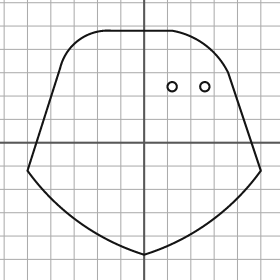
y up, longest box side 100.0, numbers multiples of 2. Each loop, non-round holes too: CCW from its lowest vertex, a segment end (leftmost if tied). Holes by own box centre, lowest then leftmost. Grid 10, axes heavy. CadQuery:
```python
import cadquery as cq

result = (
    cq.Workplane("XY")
    .moveTo(0.0, -48.0)
    .threePointArc((28.0, -34.0), (50.0, -12.0))
    .lineTo(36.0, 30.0)
    .threePointArc((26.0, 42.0), (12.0, 48.0))
    .lineTo(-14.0, 48.0)
    .threePointArc((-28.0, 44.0), (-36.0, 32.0))
    .lineTo(-50.0, -12.0)
    .threePointArc((-28.0, -34.0), (0.0, -48.0))
    .close()
    .moveTo(12.0, 24.0)
    .circle(2.0)
    .moveTo(26.0, 24.0)
    .circle(2.0)
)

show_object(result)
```